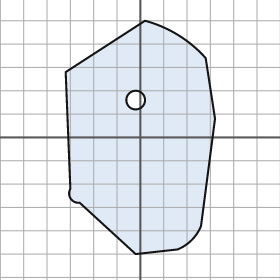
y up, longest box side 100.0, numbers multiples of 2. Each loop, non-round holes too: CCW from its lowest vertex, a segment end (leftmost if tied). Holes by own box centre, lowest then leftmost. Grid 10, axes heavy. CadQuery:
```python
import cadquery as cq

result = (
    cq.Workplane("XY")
    .moveTo(-2.0, -50.0)
    .lineTo(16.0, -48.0)
    .threePointArc((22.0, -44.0), (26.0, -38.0))
    .lineTo(32.0, 8.0)
    .lineTo(28.0, 34.0)
    .threePointArc((16.0, 44.0), (2.0, 50.0))
    .lineTo(-32.0, 28.0)
    .lineTo(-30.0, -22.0)
    .threePointArc((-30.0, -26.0), (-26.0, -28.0))
    .close()
    .moveTo(-2.0, 16.0)
    .circle(4.0)
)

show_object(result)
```